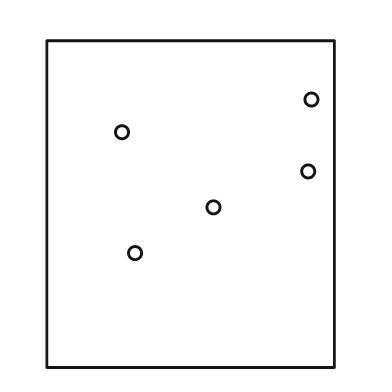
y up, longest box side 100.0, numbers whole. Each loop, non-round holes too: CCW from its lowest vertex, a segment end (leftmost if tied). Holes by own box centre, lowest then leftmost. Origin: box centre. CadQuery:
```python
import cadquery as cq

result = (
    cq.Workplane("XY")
    .moveTo(-44.0, -50.0)
    .lineTo(44.0, -50.0)
    .lineTo(44.0, 50.0)
    .lineTo(-44.0, 50.0)
    .close()
    .moveTo(-17.0, -15.0)
    .circle(2.0)
    .moveTo(7.0, -1.0)
    .circle(2.0)
    .moveTo(36.0, 10.0)
    .circle(2.0)
    .moveTo(-21.0, 22.0)
    .circle(2.0)
    .moveTo(37.0, 32.0)
    .circle(2.0)
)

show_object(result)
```